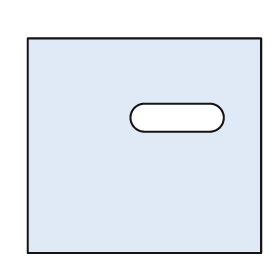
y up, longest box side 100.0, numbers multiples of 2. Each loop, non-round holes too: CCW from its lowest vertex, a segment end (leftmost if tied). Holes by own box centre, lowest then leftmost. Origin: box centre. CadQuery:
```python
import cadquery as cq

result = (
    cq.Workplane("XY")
    .moveTo(-50.0, -46.0)
    .lineTo(50.0, -46.0)
    .lineTo(50.0, 46.0)
    .lineTo(-50.0, 46.0)
    .close()
    .moveTo(0.0, 6.0)
    .lineTo(28.0, 6.0)
    .threePointArc((34.0, 12.0), (28.0, 18.0))
    .lineTo(0.0, 18.0)
    .threePointArc((-6.0, 12.0), (0.0, 6.0))
    .close()
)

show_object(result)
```